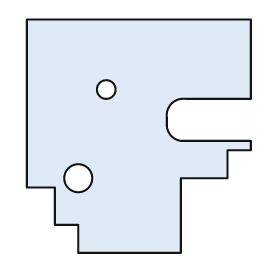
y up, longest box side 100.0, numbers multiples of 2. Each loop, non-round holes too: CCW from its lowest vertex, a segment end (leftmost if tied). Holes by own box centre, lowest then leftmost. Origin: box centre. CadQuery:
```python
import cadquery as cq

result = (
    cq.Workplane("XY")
    .moveTo(-26.0, -50.0)
    .lineTo(18.0, -50.0)
    .lineTo(18.0, -18.0)
    .lineTo(38.0, -18.0)
    .lineTo(38.0, -6.0)
    .lineTo(48.0, -6.0)
    .lineTo(48.0, -2.0)
    .lineTo(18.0, -2.0)
    .threePointArc((14.0, 0.0), (12.0, 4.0))
    .lineTo(12.0, 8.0)
    .threePointArc((14.0, 14.0), (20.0, 16.0))
    .lineTo(48.0, 16.0)
    .lineTo(48.0, 50.0)
    .lineTo(-48.0, 50.0)
    .lineTo(-48.0, -22.0)
    .lineTo(-36.0, -22.0)
    .lineTo(-36.0, -38.0)
    .lineTo(-26.0, -38.0)
    .close()
    .moveTo(-26.0, -18.0)
    .circle(6.0)
    .moveTo(-14.0, 20.0)
    .circle(4.0)
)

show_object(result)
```